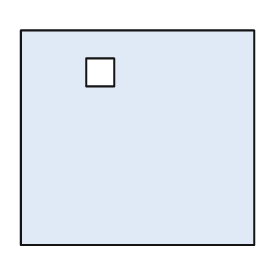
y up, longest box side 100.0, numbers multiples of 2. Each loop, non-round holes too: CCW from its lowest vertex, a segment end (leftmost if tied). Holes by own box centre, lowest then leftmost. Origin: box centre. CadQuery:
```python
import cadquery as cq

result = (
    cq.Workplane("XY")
    .moveTo(-50.0, -46.0)
    .lineTo(50.0, -46.0)
    .lineTo(50.0, 46.0)
    .lineTo(-50.0, 46.0)
    .close()
    .moveTo(-22.0, 22.0)
    .lineTo(-10.0, 22.0)
    .lineTo(-10.0, 34.0)
    .lineTo(-22.0, 34.0)
    .close()
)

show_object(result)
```